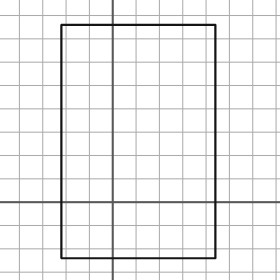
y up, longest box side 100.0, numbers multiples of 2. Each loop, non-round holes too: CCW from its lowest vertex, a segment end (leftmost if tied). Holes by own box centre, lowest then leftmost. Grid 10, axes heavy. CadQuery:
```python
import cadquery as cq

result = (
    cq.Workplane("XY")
    .moveTo(-22.0, -24.0)
    .lineTo(44.0, -24.0)
    .lineTo(44.0, 76.0)
    .lineTo(-22.0, 76.0)
    .close()
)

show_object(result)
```